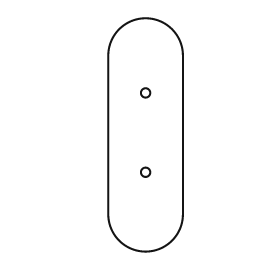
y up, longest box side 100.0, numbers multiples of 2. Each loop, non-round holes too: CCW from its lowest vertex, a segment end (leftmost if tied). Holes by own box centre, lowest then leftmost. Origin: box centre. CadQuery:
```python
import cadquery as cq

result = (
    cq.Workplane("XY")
    .moveTo(-16.0, -34.0)
    .threePointArc((0.0, -50.0), (16.0, -34.0))
    .lineTo(16.0, 34.0)
    .threePointArc((0.0, 50.0), (-16.0, 34.0))
    .close()
    .moveTo(0.0, -16.0)
    .circle(2.0)
    .moveTo(0.0, 18.0)
    .circle(2.0)
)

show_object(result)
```